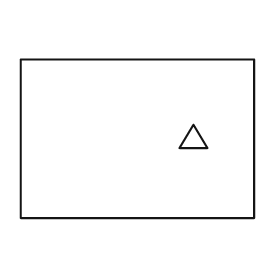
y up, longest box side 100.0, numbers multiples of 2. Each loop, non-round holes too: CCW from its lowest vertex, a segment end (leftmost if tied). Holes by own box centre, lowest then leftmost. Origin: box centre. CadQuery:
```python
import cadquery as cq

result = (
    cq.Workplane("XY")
    .moveTo(-50.0, -34.0)
    .lineTo(50.0, -34.0)
    .lineTo(50.0, 34.0)
    .lineTo(-50.0, 34.0)
    .close()
    .moveTo(18.0, -4.0)
    .lineTo(30.0, -4.0)
    .lineTo(24.0, 6.0)
    .close()
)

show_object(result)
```